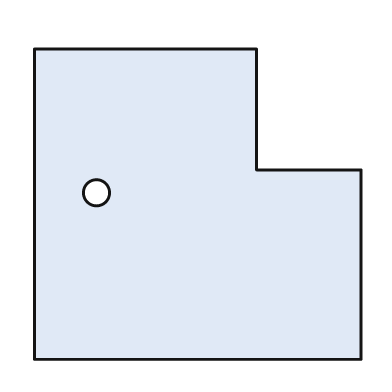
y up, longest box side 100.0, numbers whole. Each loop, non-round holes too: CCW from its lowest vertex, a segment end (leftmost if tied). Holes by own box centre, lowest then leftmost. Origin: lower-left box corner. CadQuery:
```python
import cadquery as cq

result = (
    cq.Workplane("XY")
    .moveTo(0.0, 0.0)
    .lineTo(100.0, 0.0)
    .lineTo(100.0, 58.0)
    .lineTo(68.0, 58.0)
    .lineTo(68.0, 95.0)
    .lineTo(0.0, 95.0)
    .close()
    .moveTo(19.0, 51.0)
    .circle(4.0)
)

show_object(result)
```